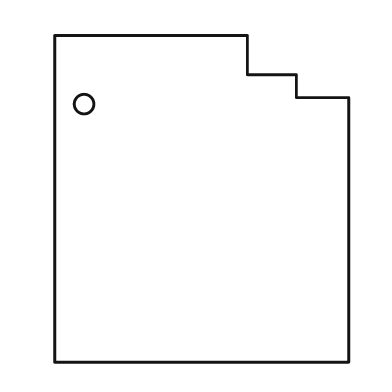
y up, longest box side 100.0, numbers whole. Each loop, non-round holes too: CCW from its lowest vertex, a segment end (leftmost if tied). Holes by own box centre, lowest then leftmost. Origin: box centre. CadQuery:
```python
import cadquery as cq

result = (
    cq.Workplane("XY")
    .moveTo(-45.0, -50.0)
    .lineTo(45.0, -50.0)
    .lineTo(45.0, 31.0)
    .lineTo(29.0, 31.0)
    .lineTo(29.0, 38.0)
    .lineTo(14.0, 38.0)
    .lineTo(14.0, 50.0)
    .lineTo(-45.0, 50.0)
    .close()
    .moveTo(-36.0, 29.0)
    .circle(3.0)
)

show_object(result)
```